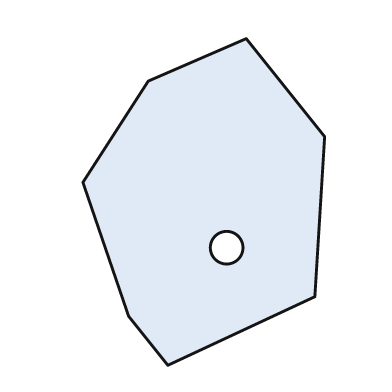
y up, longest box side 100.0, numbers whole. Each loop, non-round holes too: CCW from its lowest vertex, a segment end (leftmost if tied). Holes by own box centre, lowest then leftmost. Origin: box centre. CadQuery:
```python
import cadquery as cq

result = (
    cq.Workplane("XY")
    .moveTo(-11.0, -50.0)
    .lineTo(34.0, -29.0)
    .lineTo(37.0, 20.0)
    .lineTo(13.0, 50.0)
    .lineTo(-17.0, 37.0)
    .lineTo(-37.0, 6.0)
    .lineTo(-23.0, -35.0)
    .close()
    .moveTo(7.0, -14.0)
    .circle(5.0)
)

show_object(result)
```